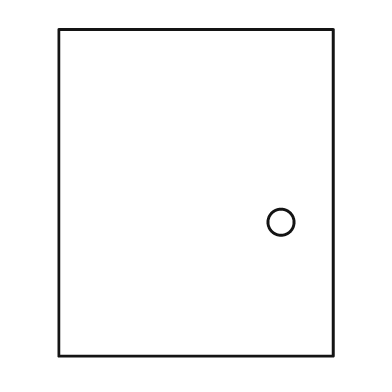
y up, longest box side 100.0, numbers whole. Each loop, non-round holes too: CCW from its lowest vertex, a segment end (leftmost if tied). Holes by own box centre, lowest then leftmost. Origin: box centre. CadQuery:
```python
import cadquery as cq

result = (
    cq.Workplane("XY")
    .moveTo(-42.0, -50.0)
    .lineTo(42.0, -50.0)
    .lineTo(42.0, 50.0)
    .lineTo(-42.0, 50.0)
    .close()
    .moveTo(26.0, -9.0)
    .circle(4.0)
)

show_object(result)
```